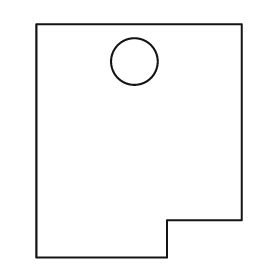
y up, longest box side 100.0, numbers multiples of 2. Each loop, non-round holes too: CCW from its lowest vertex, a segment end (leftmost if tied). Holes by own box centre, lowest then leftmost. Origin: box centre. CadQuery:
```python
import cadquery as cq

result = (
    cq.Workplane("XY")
    .moveTo(-44.0, -50.0)
    .lineTo(12.0, -50.0)
    .lineTo(12.0, -34.0)
    .lineTo(44.0, -34.0)
    .lineTo(44.0, 50.0)
    .lineTo(-44.0, 50.0)
    .close()
    .moveTo(-2.0, 34.0)
    .circle(10.0)
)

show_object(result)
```